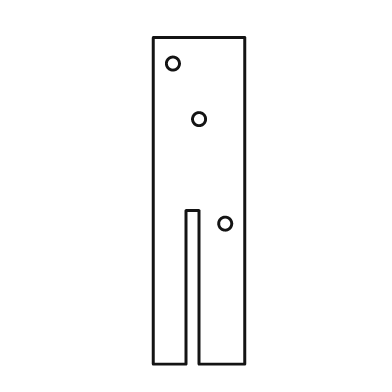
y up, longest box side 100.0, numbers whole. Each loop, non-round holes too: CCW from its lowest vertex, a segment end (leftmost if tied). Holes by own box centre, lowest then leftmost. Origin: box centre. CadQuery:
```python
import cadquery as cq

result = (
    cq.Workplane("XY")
    .moveTo(-14.0, -50.0)
    .lineTo(-4.0, -50.0)
    .lineTo(-4.0, -3.0)
    .lineTo(0.0, -3.0)
    .lineTo(0.0, -50.0)
    .lineTo(14.0, -50.0)
    .lineTo(14.0, 50.0)
    .lineTo(-14.0, 50.0)
    .close()
    .moveTo(8.0, -7.0)
    .circle(2.0)
    .moveTo(0.0, 25.0)
    .circle(2.0)
    .moveTo(-8.0, 42.0)
    .circle(2.0)
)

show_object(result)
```